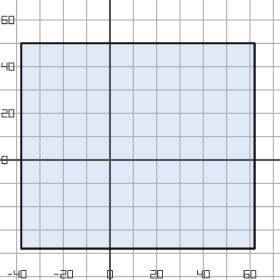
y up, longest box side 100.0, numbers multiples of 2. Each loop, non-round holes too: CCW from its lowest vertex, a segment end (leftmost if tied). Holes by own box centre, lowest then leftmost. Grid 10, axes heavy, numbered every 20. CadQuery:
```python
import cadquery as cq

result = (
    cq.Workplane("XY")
    .moveTo(-38.0, -38.0)
    .lineTo(62.0, -38.0)
    .lineTo(62.0, 50.0)
    .lineTo(-38.0, 50.0)
    .close()
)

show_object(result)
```